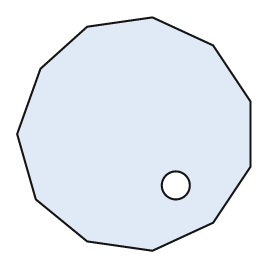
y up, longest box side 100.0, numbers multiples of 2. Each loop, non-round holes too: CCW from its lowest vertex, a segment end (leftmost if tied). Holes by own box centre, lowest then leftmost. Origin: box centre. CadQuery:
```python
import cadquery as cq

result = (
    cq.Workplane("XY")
    .moveTo(8.0, -50.0)
    .lineTo(34.0, -38.0)
    .lineTo(50.0, -14.0)
    .lineTo(50.0, 14.0)
    .lineTo(34.0, 38.0)
    .lineTo(8.0, 50.0)
    .lineTo(-20.0, 46.0)
    .lineTo(-40.0, 28.0)
    .lineTo(-50.0, 0.0)
    .lineTo(-42.0, -28.0)
    .lineTo(-20.0, -46.0)
    .close()
    .moveTo(18.0, -22.0)
    .circle(6.0)
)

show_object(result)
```